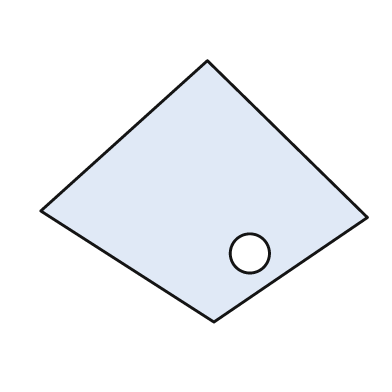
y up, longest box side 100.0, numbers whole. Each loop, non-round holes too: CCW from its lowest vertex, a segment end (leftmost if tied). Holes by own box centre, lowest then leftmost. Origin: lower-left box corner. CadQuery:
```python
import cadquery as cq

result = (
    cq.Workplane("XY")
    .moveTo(53.0, 0.0)
    .lineTo(100.0, 32.0)
    .lineTo(51.0, 80.0)
    .lineTo(0.0, 34.0)
    .close()
    .moveTo(64.0, 21.0)
    .circle(6.0)
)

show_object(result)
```